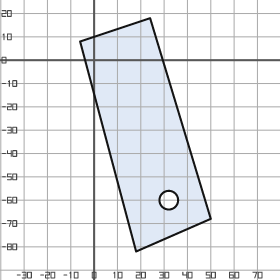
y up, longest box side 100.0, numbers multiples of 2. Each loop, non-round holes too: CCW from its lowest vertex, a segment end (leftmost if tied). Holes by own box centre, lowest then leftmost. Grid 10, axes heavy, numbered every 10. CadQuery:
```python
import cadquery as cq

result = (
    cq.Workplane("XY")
    .moveTo(18.0, -82.0)
    .lineTo(50.0, -68.0)
    .lineTo(24.0, 18.0)
    .lineTo(-6.0, 8.0)
    .close()
    .moveTo(32.0, -60.0)
    .circle(4.0)
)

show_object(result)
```